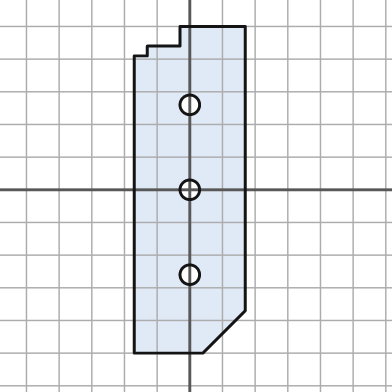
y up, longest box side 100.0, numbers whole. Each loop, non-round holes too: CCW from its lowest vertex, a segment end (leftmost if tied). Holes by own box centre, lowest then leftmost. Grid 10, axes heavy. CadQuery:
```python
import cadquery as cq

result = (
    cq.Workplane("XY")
    .moveTo(-17.0, -50.0)
    .lineTo(4.0, -50.0)
    .lineTo(17.0, -37.0)
    .lineTo(17.0, 50.0)
    .lineTo(-3.0, 50.0)
    .lineTo(-3.0, 44.0)
    .lineTo(-13.0, 44.0)
    .lineTo(-13.0, 41.0)
    .lineTo(-17.0, 41.0)
    .close()
    .moveTo(0.0, -26.0)
    .circle(3.0)
    .moveTo(0.0, 0.0)
    .circle(3.0)
    .moveTo(0.0, 26.0)
    .circle(3.0)
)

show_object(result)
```